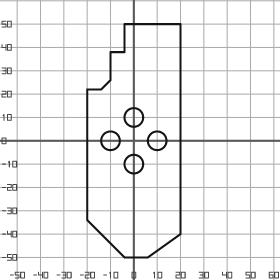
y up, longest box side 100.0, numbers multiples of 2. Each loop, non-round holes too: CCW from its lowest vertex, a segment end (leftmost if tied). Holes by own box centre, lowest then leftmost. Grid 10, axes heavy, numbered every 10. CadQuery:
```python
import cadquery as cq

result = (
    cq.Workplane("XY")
    .moveTo(-4.0, -50.0)
    .lineTo(6.0, -50.0)
    .lineTo(20.0, -40.0)
    .lineTo(20.0, 50.0)
    .lineTo(-4.0, 50.0)
    .lineTo(-4.0, 38.0)
    .lineTo(-10.0, 38.0)
    .lineTo(-10.0, 26.0)
    .lineTo(-14.0, 22.0)
    .lineTo(-20.0, 22.0)
    .lineTo(-20.0, -34.0)
    .close()
    .moveTo(0.0, -10.0)
    .circle(4.0)
    .moveTo(-10.0, 0.0)
    .circle(4.0)
    .moveTo(10.0, 0.0)
    .circle(4.0)
    .moveTo(0.0, 10.0)
    .circle(4.0)
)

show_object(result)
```